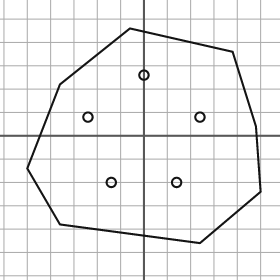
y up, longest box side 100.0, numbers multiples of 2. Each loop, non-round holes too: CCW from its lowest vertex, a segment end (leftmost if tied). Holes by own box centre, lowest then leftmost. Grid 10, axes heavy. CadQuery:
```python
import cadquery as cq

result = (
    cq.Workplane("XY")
    .moveTo(24.0, -46.0)
    .lineTo(50.0, -24.0)
    .lineTo(48.0, 4.0)
    .lineTo(38.0, 36.0)
    .lineTo(-6.0, 46.0)
    .lineTo(-36.0, 22.0)
    .lineTo(-50.0, -14.0)
    .lineTo(-36.0, -38.0)
    .close()
    .moveTo(-14.0, -20.0)
    .circle(2.0)
    .moveTo(14.0, -20.0)
    .circle(2.0)
    .moveTo(-24.0, 8.0)
    .circle(2.0)
    .moveTo(24.0, 8.0)
    .circle(2.0)
    .moveTo(0.0, 26.0)
    .circle(2.0)
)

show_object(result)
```